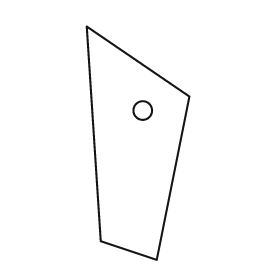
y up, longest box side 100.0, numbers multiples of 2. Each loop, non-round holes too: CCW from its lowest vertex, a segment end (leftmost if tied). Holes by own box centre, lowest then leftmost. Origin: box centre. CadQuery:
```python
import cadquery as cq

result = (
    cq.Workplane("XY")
    .moveTo(8.0, -50.0)
    .lineTo(22.0, 20.0)
    .lineTo(-22.0, 50.0)
    .lineTo(-16.0, -42.0)
    .close()
    .moveTo(2.0, 14.0)
    .circle(4.0)
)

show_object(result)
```